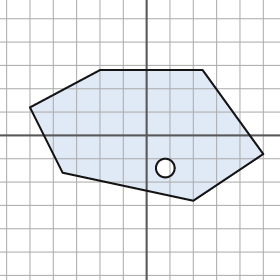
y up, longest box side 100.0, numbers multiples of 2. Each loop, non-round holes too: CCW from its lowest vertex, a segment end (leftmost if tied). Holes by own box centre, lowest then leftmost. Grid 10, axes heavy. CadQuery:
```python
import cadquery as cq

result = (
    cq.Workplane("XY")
    .moveTo(20.0, -28.0)
    .lineTo(50.0, -8.0)
    .lineTo(24.0, 28.0)
    .lineTo(-20.0, 28.0)
    .lineTo(-50.0, 12.0)
    .lineTo(-36.0, -16.0)
    .close()
    .moveTo(8.0, -14.0)
    .circle(4.0)
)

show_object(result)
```